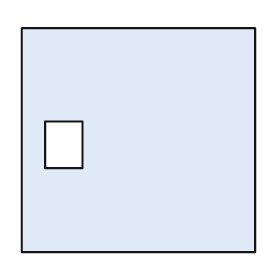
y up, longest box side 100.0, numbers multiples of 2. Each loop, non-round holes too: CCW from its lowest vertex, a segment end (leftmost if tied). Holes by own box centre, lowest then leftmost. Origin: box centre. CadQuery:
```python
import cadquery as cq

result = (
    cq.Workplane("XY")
    .moveTo(-50.0, -48.0)
    .lineTo(50.0, -48.0)
    .lineTo(50.0, 48.0)
    .lineTo(-50.0, 48.0)
    .close()
    .moveTo(-40.0, -12.0)
    .lineTo(-24.0, -12.0)
    .lineTo(-24.0, 8.0)
    .lineTo(-40.0, 8.0)
    .close()
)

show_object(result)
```